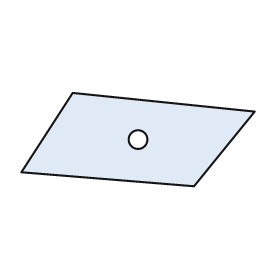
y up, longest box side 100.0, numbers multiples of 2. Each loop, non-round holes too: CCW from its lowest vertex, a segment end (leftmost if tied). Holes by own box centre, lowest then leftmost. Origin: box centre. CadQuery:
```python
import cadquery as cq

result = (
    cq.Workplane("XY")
    .moveTo(24.0, -20.0)
    .lineTo(50.0, 12.0)
    .lineTo(-28.0, 20.0)
    .lineTo(-50.0, -14.0)
    .close()
    .moveTo(0.0, 0.0)
    .circle(4.0)
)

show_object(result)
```